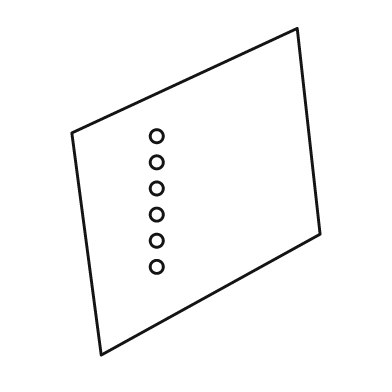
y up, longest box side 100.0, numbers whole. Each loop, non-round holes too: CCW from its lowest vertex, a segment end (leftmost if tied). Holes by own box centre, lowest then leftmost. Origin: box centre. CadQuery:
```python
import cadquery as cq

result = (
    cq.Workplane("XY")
    .moveTo(-29.0, -50.0)
    .lineTo(38.0, -13.0)
    .lineTo(31.0, 50.0)
    .lineTo(-38.0, 18.0)
    .close()
    .moveTo(-12.0, -23.0)
    .circle(2.0)
    .moveTo(-12.0, -15.0)
    .circle(2.0)
    .moveTo(-12.0, -7.0)
    .circle(2.0)
    .moveTo(-12.0, 1.0)
    .circle(2.0)
    .moveTo(-12.0, 9.0)
    .circle(2.0)
    .moveTo(-12.0, 17.0)
    .circle(2.0)
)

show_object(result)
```